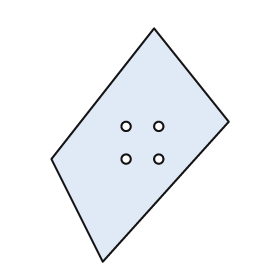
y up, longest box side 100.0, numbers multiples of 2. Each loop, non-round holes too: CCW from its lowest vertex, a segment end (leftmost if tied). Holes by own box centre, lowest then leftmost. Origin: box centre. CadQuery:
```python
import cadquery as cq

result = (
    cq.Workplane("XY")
    .moveTo(-16.0, -50.0)
    .lineTo(38.0, 10.0)
    .lineTo(6.0, 50.0)
    .lineTo(-38.0, -6.0)
    .close()
    .moveTo(-6.0, -6.0)
    .circle(2.0)
    .moveTo(8.0, -6.0)
    .circle(2.0)
    .moveTo(-6.0, 8.0)
    .circle(2.0)
    .moveTo(8.0, 8.0)
    .circle(2.0)
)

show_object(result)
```